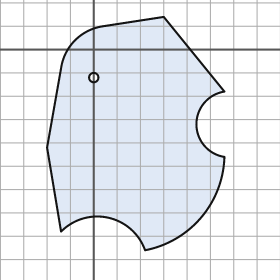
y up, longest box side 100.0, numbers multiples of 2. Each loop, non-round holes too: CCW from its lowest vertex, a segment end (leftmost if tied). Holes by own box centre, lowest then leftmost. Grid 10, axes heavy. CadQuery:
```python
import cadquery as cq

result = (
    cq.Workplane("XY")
    .moveTo(22.0, -86.0)
    .threePointArc((46.0, -72.0), (56.0, -46.0))
    .threePointArc((44.0, -32.0), (56.0, -18.0))
    .lineTo(30.0, 14.0)
    .lineTo(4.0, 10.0)
    .threePointArc((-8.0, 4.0), (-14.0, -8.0))
    .lineTo(-20.0, -42.0)
    .lineTo(-14.0, -78.0)
    .threePointArc((6.0, -72.0), (22.0, -86.0))
    .close()
    .moveTo(0.0, -12.0)
    .circle(2.0)
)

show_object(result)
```